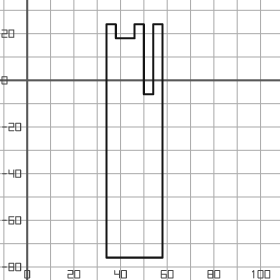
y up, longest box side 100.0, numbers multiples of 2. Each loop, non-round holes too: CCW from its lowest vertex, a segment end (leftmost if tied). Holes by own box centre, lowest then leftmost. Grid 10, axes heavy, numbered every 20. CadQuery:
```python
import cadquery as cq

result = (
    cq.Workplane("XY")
    .moveTo(34.0, -76.0)
    .lineTo(58.0, -76.0)
    .lineTo(58.0, 24.0)
    .lineTo(54.0, 24.0)
    .lineTo(54.0, -6.0)
    .lineTo(50.0, -6.0)
    .lineTo(50.0, 24.0)
    .lineTo(46.0, 24.0)
    .lineTo(46.0, 18.0)
    .lineTo(38.0, 18.0)
    .lineTo(38.0, 24.0)
    .lineTo(34.0, 24.0)
    .close()
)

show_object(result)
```